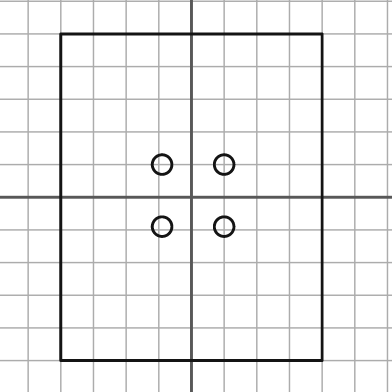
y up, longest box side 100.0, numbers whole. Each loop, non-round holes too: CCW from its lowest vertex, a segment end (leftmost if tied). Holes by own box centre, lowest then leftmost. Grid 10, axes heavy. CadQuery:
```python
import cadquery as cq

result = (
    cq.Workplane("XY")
    .moveTo(-40.0, -50.0)
    .lineTo(40.0, -50.0)
    .lineTo(40.0, 50.0)
    .lineTo(-40.0, 50.0)
    .close()
    .moveTo(-9.0, -9.0)
    .circle(3.0)
    .moveTo(10.0, -9.0)
    .circle(3.0)
    .moveTo(-9.0, 10.0)
    .circle(3.0)
    .moveTo(10.0, 10.0)
    .circle(3.0)
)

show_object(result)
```